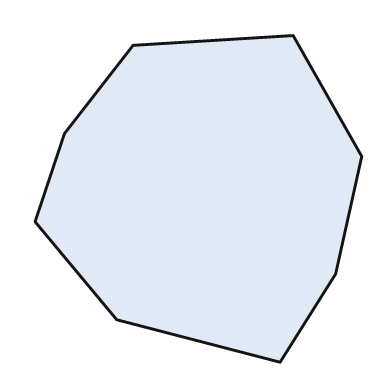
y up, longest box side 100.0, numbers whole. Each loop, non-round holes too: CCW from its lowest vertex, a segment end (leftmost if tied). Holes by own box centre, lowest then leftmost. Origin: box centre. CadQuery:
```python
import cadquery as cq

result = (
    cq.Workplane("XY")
    .moveTo(25.0, -50.0)
    .lineTo(42.0, -23.0)
    .lineTo(50.0, 13.0)
    .lineTo(29.0, 50.0)
    .lineTo(-20.0, 47.0)
    .lineTo(-41.0, 20.0)
    .lineTo(-50.0, -7.0)
    .lineTo(-25.0, -37.0)
    .close()
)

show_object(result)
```